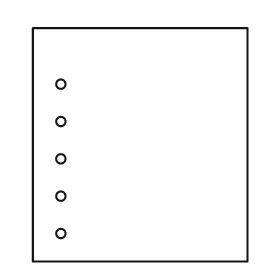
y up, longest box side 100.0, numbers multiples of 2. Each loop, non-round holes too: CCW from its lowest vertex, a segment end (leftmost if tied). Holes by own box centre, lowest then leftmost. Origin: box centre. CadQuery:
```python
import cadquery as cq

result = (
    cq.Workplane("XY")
    .moveTo(-46.0, -50.0)
    .lineTo(46.0, -50.0)
    .lineTo(46.0, 50.0)
    .lineTo(-46.0, 50.0)
    .close()
    .moveTo(-34.0, -38.0)
    .circle(2.0)
    .moveTo(-34.0, -22.0)
    .circle(2.0)
    .moveTo(-34.0, -6.0)
    .circle(2.0)
    .moveTo(-34.0, 10.0)
    .circle(2.0)
    .moveTo(-34.0, 26.0)
    .circle(2.0)
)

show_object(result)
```